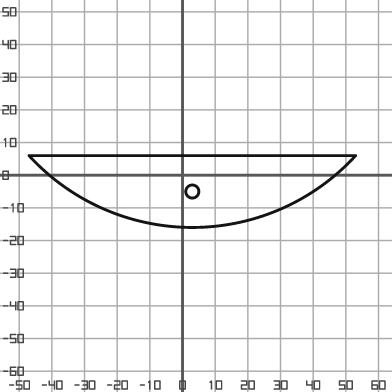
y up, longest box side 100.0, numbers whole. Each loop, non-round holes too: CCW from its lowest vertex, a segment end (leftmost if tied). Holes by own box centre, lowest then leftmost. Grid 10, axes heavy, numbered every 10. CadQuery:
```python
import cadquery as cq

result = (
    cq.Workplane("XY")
    .moveTo(-47.0, 6.0)
    .threePointArc((3.0, -16.0), (53.0, 6.0))
    .close()
    .moveTo(3.0, -5.0)
    .circle(2.0)
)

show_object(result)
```